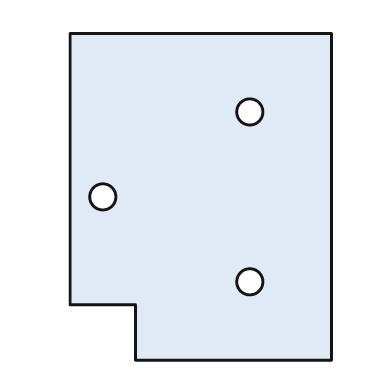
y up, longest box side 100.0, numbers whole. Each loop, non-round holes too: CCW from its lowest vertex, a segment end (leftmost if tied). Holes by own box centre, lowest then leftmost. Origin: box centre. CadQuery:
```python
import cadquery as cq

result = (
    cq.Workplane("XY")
    .moveTo(-20.0, -50.0)
    .lineTo(40.0, -50.0)
    .lineTo(40.0, 50.0)
    .lineTo(-40.0, 50.0)
    .lineTo(-40.0, -33.0)
    .lineTo(-20.0, -33.0)
    .close()
    .moveTo(15.0, -26.0)
    .circle(4.0)
    .moveTo(-30.0, 0.0)
    .circle(4.0)
    .moveTo(15.0, 26.0)
    .circle(4.0)
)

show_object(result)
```